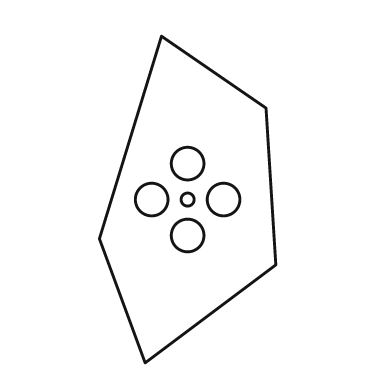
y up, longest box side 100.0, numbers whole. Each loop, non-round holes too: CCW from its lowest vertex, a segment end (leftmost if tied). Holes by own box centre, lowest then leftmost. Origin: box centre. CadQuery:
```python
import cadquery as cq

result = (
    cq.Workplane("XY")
    .moveTo(-13.0, -50.0)
    .lineTo(27.0, -20.0)
    .lineTo(24.0, 28.0)
    .lineTo(-8.0, 50.0)
    .lineTo(-27.0, -12.0)
    .close()
    .moveTo(0.0, -11.0)
    .circle(5.0)
    .moveTo(-11.0, 0.0)
    .circle(5.0)
    .moveTo(0.0, 0.0)
    .circle(2.0)
    .moveTo(11.0, 0.0)
    .circle(5.0)
    .moveTo(0.0, 11.0)
    .circle(5.0)
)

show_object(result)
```